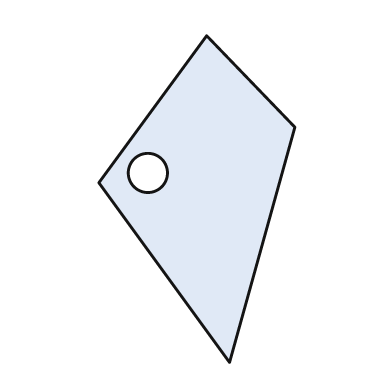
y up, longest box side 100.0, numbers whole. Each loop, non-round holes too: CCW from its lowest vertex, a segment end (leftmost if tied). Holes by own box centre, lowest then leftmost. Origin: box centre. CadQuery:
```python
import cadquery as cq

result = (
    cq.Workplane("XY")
    .moveTo(10.0, -50.0)
    .lineTo(30.0, 22.0)
    .lineTo(3.0, 50.0)
    .lineTo(-30.0, 5.0)
    .close()
    .moveTo(-15.0, 8.0)
    .circle(6.0)
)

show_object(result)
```